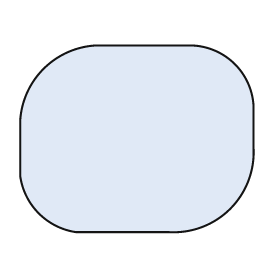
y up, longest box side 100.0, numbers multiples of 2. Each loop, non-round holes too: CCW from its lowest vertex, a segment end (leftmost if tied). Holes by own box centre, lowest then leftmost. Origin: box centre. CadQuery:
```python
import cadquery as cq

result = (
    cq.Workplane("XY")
    .moveTo(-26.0, -40.0)
    .lineTo(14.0, -40.0)
    .threePointArc((40.0, -30.0), (50.0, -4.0))
    .lineTo(50.0, 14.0)
    .threePointArc((42.0, 32.0), (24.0, 40.0))
    .lineTo(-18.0, 40.0)
    .threePointArc((-40.0, 30.0), (-50.0, 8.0))
    .lineTo(-50.0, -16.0)
    .threePointArc((-42.0, -32.0), (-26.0, -40.0))
    .close()
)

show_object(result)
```